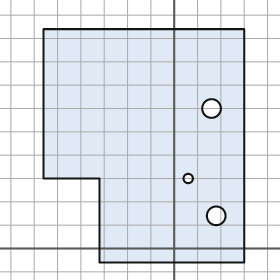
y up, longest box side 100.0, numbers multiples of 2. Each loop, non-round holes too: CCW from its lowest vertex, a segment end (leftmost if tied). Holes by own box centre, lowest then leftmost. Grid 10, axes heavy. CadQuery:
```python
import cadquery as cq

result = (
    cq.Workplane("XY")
    .moveTo(-32.0, -6.0)
    .lineTo(30.0, -6.0)
    .lineTo(30.0, 94.0)
    .lineTo(-56.0, 94.0)
    .lineTo(-56.0, 30.0)
    .lineTo(-32.0, 30.0)
    .close()
    .moveTo(18.0, 14.0)
    .circle(4.0)
    .moveTo(6.0, 30.0)
    .circle(2.0)
    .moveTo(16.0, 60.0)
    .circle(4.0)
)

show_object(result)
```